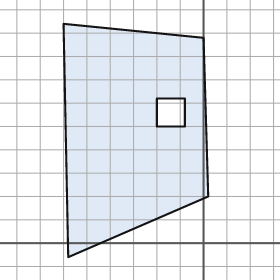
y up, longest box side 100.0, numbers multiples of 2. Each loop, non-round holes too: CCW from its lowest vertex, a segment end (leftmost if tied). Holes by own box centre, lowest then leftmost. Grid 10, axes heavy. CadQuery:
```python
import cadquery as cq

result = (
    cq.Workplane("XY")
    .moveTo(-58.0, -6.0)
    .lineTo(2.0, 20.0)
    .lineTo(0.0, 88.0)
    .lineTo(-60.0, 94.0)
    .close()
    .moveTo(-20.0, 50.0)
    .lineTo(-8.0, 50.0)
    .lineTo(-8.0, 62.0)
    .lineTo(-20.0, 62.0)
    .close()
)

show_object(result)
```